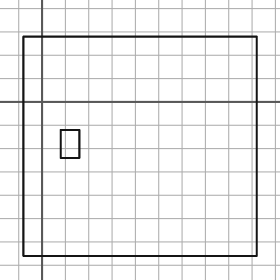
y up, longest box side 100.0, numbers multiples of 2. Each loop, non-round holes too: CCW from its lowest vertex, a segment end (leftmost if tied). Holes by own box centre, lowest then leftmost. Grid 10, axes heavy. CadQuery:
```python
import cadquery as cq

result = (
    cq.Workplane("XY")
    .moveTo(-8.0, -66.0)
    .lineTo(92.0, -66.0)
    .lineTo(92.0, 28.0)
    .lineTo(-8.0, 28.0)
    .close()
    .moveTo(8.0, -24.0)
    .lineTo(16.0, -24.0)
    .lineTo(16.0, -12.0)
    .lineTo(8.0, -12.0)
    .close()
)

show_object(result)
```